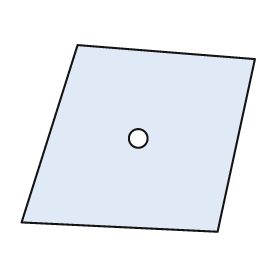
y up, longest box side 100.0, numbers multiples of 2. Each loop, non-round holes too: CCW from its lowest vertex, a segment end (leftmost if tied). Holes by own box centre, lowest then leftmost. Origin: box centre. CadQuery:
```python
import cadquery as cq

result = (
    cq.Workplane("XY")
    .moveTo(34.0, -40.0)
    .lineTo(50.0, 34.0)
    .lineTo(-26.0, 40.0)
    .lineTo(-50.0, -36.0)
    .close()
    .moveTo(0.0, 0.0)
    .circle(4.0)
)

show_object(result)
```